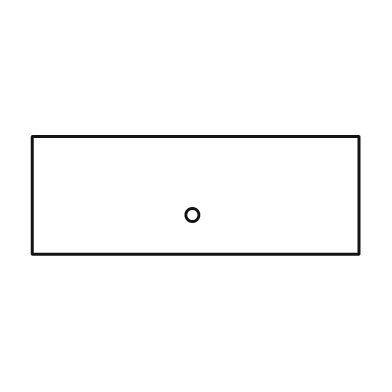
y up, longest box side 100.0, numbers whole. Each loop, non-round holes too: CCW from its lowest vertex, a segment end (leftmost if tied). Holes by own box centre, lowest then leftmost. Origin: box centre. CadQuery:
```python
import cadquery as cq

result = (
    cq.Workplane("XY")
    .moveTo(-50.0, -18.0)
    .lineTo(50.0, -18.0)
    .lineTo(50.0, 18.0)
    .lineTo(-50.0, 18.0)
    .close()
    .moveTo(-1.0, -6.0)
    .circle(2.0)
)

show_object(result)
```